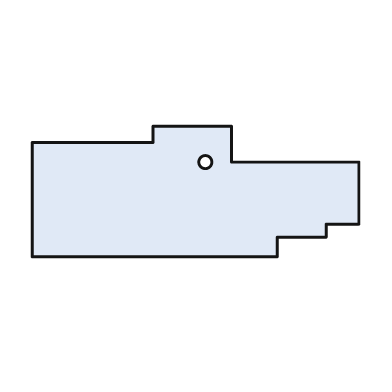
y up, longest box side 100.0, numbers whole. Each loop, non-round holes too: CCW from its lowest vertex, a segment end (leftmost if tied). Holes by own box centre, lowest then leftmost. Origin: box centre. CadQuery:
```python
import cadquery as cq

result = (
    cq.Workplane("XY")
    .moveTo(-50.0, -20.0)
    .lineTo(25.0, -20.0)
    .lineTo(25.0, -14.0)
    .lineTo(40.0, -14.0)
    .lineTo(40.0, -10.0)
    .lineTo(50.0, -10.0)
    .lineTo(50.0, 9.0)
    .lineTo(11.0, 9.0)
    .lineTo(11.0, 20.0)
    .lineTo(-13.0, 20.0)
    .lineTo(-13.0, 15.0)
    .lineTo(-50.0, 15.0)
    .close()
    .moveTo(3.0, 9.0)
    .circle(2.0)
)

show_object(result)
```